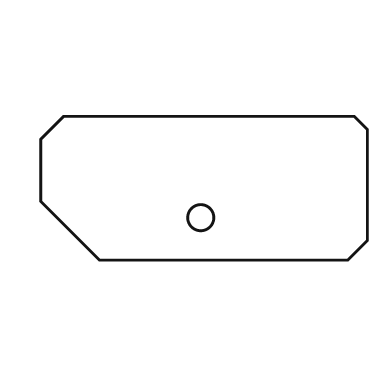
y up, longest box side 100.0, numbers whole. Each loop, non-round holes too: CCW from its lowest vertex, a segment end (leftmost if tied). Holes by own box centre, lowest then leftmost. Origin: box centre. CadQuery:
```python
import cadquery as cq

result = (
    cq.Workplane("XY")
    .moveTo(-32.0, -22.0)
    .lineTo(44.0, -22.0)
    .lineTo(50.0, -16.0)
    .lineTo(50.0, 18.0)
    .lineTo(46.0, 22.0)
    .lineTo(-43.0, 22.0)
    .lineTo(-50.0, 15.0)
    .lineTo(-50.0, -4.0)
    .close()
    .moveTo(-1.0, -9.0)
    .circle(4.0)
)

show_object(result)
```